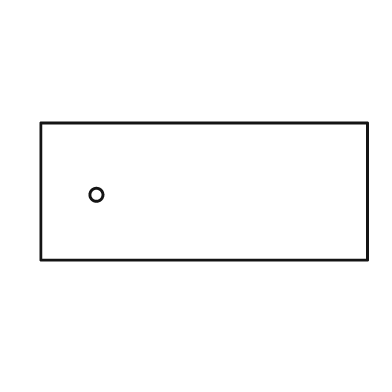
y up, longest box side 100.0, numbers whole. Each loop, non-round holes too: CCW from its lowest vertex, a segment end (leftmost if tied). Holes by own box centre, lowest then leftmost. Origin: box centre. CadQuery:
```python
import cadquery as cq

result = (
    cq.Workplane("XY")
    .moveTo(-50.0, -21.0)
    .lineTo(50.0, -21.0)
    .lineTo(50.0, 21.0)
    .lineTo(-50.0, 21.0)
    .close()
    .moveTo(-33.0, -1.0)
    .circle(2.0)
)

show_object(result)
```